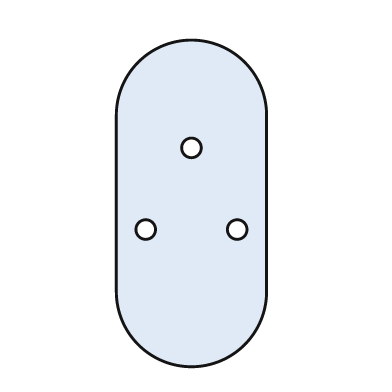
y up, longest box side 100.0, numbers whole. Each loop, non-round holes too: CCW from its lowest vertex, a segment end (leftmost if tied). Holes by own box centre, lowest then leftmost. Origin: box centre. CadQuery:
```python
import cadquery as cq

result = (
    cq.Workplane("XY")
    .moveTo(-23.0, -27.0)
    .threePointArc((0.0, -50.0), (23.0, -27.0))
    .lineTo(23.0, 27.0)
    .threePointArc((0.0, 50.0), (-23.0, 27.0))
    .close()
    .moveTo(-14.0, -8.0)
    .circle(3.0)
    .moveTo(14.0, -8.0)
    .circle(3.0)
    .moveTo(0.0, 17.0)
    .circle(3.0)
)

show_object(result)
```